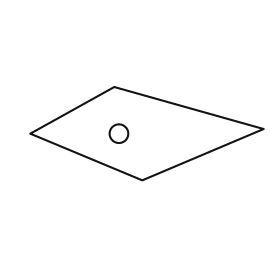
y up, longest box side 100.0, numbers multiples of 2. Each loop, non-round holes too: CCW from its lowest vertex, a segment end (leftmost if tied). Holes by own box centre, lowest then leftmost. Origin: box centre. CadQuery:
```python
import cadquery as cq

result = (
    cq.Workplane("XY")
    .moveTo(-2.0, -20.0)
    .lineTo(50.0, 2.0)
    .lineTo(-14.0, 20.0)
    .lineTo(-50.0, 0.0)
    .close()
    .moveTo(-12.0, 0.0)
    .circle(4.0)
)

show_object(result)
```